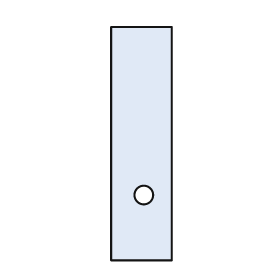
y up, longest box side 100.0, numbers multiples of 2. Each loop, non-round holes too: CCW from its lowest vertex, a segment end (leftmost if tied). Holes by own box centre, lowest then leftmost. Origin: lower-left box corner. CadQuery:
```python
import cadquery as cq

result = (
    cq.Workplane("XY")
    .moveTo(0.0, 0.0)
    .lineTo(26.0, 0.0)
    .lineTo(26.0, 100.0)
    .lineTo(0.0, 100.0)
    .close()
    .moveTo(14.0, 28.0)
    .circle(4.0)
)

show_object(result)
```